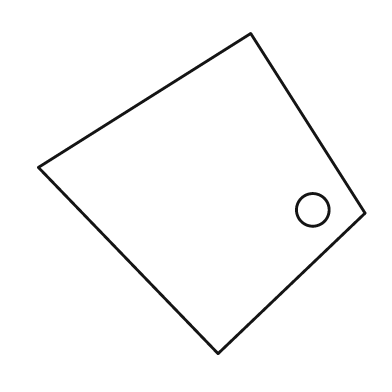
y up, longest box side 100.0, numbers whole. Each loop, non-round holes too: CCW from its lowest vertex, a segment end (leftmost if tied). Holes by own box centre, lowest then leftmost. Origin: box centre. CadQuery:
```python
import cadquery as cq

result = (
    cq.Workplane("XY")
    .moveTo(5.0, -49.0)
    .lineTo(50.0, -6.0)
    .lineTo(15.0, 49.0)
    .lineTo(-50.0, 8.0)
    .close()
    .moveTo(34.0, -5.0)
    .circle(5.0)
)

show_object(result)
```